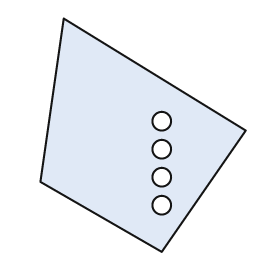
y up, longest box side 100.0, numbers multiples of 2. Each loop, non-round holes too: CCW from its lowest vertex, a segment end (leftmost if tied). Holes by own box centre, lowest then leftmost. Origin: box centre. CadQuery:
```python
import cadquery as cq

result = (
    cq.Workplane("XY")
    .moveTo(8.0, -50.0)
    .lineTo(44.0, 2.0)
    .lineTo(-34.0, 50.0)
    .lineTo(-44.0, -20.0)
    .close()
    .moveTo(8.0, -30.0)
    .circle(4.0)
    .moveTo(8.0, -18.0)
    .circle(4.0)
    .moveTo(8.0, -6.0)
    .circle(4.0)
    .moveTo(8.0, 6.0)
    .circle(4.0)
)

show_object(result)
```